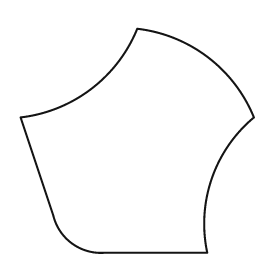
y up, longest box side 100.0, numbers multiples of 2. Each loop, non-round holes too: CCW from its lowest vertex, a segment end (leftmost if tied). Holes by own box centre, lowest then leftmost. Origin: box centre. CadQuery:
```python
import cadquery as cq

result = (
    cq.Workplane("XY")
    .moveTo(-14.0, -48.0)
    .lineTo(30.0, -48.0)
    .threePointArc((32.0, -16.0), (50.0, 10.0))
    .threePointArc((30.0, 36.0), (0.0, 48.0))
    .threePointArc((-20.0, 22.0), (-50.0, 10.0))
    .lineTo(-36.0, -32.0)
    .threePointArc((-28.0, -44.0), (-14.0, -48.0))
    .close()
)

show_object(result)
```